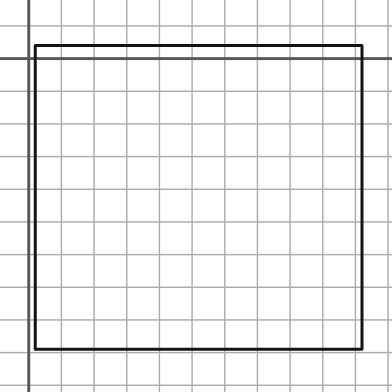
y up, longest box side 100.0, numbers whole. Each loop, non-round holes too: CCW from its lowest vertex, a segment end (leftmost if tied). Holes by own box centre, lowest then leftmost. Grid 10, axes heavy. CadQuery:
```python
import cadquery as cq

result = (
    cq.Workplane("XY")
    .moveTo(2.0, -89.0)
    .lineTo(102.0, -89.0)
    .lineTo(102.0, 4.0)
    .lineTo(2.0, 4.0)
    .close()
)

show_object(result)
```